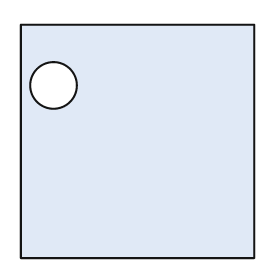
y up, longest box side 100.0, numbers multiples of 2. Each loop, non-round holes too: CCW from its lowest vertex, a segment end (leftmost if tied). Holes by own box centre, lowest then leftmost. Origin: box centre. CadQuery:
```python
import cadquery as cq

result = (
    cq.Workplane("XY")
    .moveTo(-50.0, -50.0)
    .lineTo(50.0, -50.0)
    .lineTo(50.0, 50.0)
    .lineTo(-50.0, 50.0)
    .close()
    .moveTo(-36.0, 24.0)
    .circle(10.0)
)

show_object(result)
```